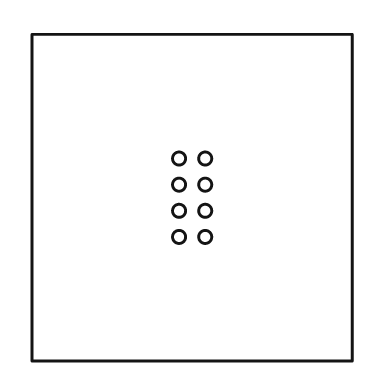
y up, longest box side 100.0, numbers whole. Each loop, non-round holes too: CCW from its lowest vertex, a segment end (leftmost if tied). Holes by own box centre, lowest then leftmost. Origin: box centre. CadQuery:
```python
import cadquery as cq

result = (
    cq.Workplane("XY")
    .moveTo(-49.0, -50.0)
    .lineTo(49.0, -50.0)
    .lineTo(49.0, 50.0)
    .lineTo(-49.0, 50.0)
    .close()
    .moveTo(-4.0, -12.0)
    .circle(2.0)
    .moveTo(4.0, -12.0)
    .circle(2.0)
    .moveTo(-4.0, -4.0)
    .circle(2.0)
    .moveTo(4.0, -4.0)
    .circle(2.0)
    .moveTo(-4.0, 4.0)
    .circle(2.0)
    .moveTo(4.0, 4.0)
    .circle(2.0)
    .moveTo(-4.0, 12.0)
    .circle(2.0)
    .moveTo(4.0, 12.0)
    .circle(2.0)
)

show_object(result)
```